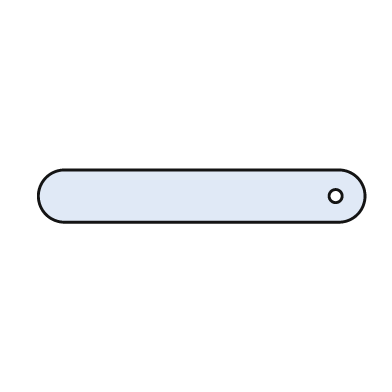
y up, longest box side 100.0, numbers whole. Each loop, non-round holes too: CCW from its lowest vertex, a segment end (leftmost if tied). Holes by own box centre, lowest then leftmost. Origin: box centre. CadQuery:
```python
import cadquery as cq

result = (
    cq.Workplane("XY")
    .moveTo(-42.0, -8.0)
    .lineTo(42.0, -8.0)
    .threePointArc((50.0, 0.0), (42.0, 8.0))
    .lineTo(-42.0, 8.0)
    .threePointArc((-50.0, 0.0), (-42.0, -8.0))
    .close()
    .moveTo(41.0, 0.0)
    .circle(2.0)
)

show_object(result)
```